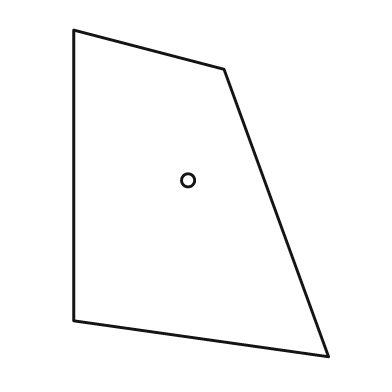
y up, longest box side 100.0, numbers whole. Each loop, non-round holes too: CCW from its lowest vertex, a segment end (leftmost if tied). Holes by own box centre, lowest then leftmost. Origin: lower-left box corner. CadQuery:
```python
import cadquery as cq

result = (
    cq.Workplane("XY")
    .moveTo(78.0, 0.0)
    .lineTo(46.0, 88.0)
    .lineTo(0.0, 100.0)
    .lineTo(0.0, 11.0)
    .close()
    .moveTo(35.0, 54.0)
    .circle(2.0)
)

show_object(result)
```